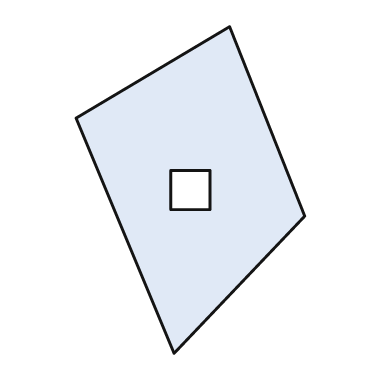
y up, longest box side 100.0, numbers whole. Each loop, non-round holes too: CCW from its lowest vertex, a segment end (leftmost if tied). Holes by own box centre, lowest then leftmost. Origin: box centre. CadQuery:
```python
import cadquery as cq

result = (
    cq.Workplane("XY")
    .moveTo(-5.0, -50.0)
    .lineTo(35.0, -8.0)
    .lineTo(12.0, 50.0)
    .lineTo(-35.0, 22.0)
    .close()
    .moveTo(-6.0, -6.0)
    .lineTo(6.0, -6.0)
    .lineTo(6.0, 6.0)
    .lineTo(-6.0, 6.0)
    .close()
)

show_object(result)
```